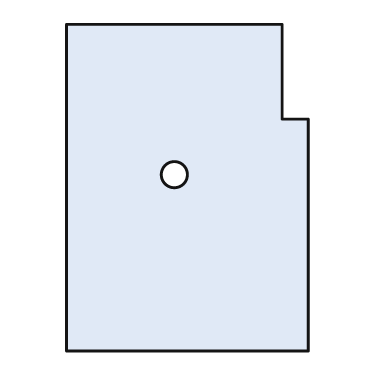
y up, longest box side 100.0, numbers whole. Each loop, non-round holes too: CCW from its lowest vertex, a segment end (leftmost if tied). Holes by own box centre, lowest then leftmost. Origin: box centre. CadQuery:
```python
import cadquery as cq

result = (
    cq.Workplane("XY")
    .moveTo(-37.0, -50.0)
    .lineTo(37.0, -50.0)
    .lineTo(37.0, 21.0)
    .lineTo(29.0, 21.0)
    .lineTo(29.0, 50.0)
    .lineTo(-37.0, 50.0)
    .close()
    .moveTo(-4.0, 4.0)
    .circle(4.0)
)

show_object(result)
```